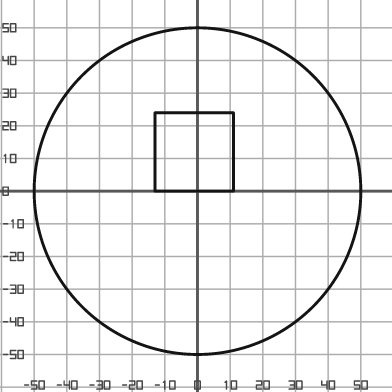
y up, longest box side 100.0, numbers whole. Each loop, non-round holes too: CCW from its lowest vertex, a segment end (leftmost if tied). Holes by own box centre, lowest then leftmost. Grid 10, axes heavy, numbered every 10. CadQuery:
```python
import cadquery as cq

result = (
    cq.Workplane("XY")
    .moveTo(0.0, 0.0)
    .circle(50.0)
    .moveTo(-13.0, 0.0)
    .lineTo(11.0, 0.0)
    .lineTo(11.0, 24.0)
    .lineTo(-13.0, 24.0)
    .close()
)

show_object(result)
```